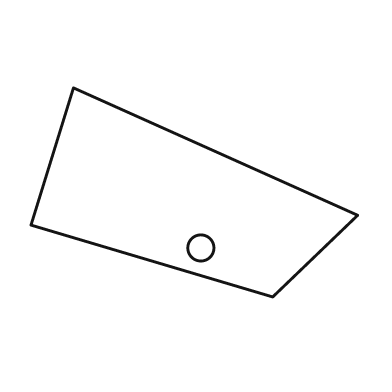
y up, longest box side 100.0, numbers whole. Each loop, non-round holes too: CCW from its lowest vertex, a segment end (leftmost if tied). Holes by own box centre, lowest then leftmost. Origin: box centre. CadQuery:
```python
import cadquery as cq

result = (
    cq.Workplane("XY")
    .moveTo(24.0, -32.0)
    .lineTo(50.0, -7.0)
    .lineTo(-37.0, 32.0)
    .lineTo(-50.0, -10.0)
    .close()
    .moveTo(2.0, -17.0)
    .circle(4.0)
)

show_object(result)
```